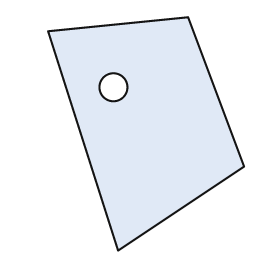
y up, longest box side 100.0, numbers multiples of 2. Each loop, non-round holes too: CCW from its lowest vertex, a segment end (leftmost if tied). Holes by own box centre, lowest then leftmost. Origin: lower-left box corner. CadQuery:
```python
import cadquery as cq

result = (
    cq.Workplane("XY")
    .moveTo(30.0, 0.0)
    .lineTo(84.0, 36.0)
    .lineTo(60.0, 100.0)
    .lineTo(0.0, 94.0)
    .close()
    .moveTo(28.0, 70.0)
    .circle(6.0)
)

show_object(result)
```